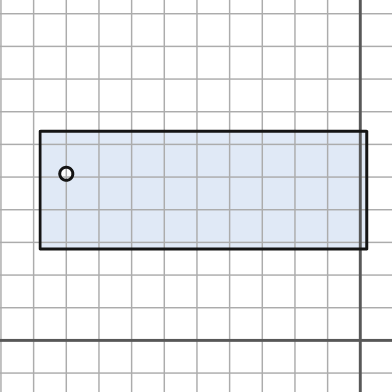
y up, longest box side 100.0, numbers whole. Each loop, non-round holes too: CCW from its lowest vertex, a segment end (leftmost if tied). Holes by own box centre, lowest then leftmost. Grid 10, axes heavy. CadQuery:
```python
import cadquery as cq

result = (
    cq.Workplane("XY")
    .moveTo(-98.0, 28.0)
    .lineTo(2.0, 28.0)
    .lineTo(2.0, 64.0)
    .lineTo(-98.0, 64.0)
    .close()
    .moveTo(-90.0, 51.0)
    .circle(2.0)
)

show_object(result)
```